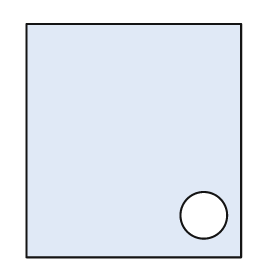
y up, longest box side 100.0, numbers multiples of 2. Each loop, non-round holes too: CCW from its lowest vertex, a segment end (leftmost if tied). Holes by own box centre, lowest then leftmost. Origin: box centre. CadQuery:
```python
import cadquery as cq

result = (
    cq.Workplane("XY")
    .moveTo(-46.0, -50.0)
    .lineTo(46.0, -50.0)
    .lineTo(46.0, 50.0)
    .lineTo(-46.0, 50.0)
    .close()
    .moveTo(30.0, -32.0)
    .circle(10.0)
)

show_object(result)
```